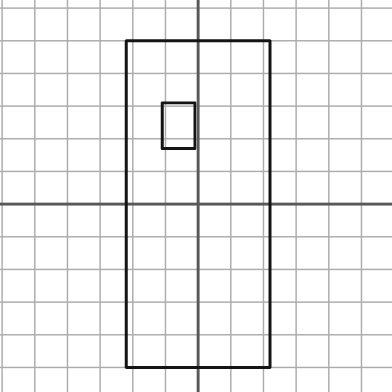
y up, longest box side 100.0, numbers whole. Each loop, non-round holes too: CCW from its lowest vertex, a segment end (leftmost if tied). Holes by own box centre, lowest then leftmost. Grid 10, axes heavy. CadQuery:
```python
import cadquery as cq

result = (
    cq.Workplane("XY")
    .moveTo(-22.0, -50.0)
    .lineTo(22.0, -50.0)
    .lineTo(22.0, 50.0)
    .lineTo(-22.0, 50.0)
    .close()
    .moveTo(-11.0, 17.0)
    .lineTo(-1.0, 17.0)
    .lineTo(-1.0, 31.0)
    .lineTo(-11.0, 31.0)
    .close()
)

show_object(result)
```